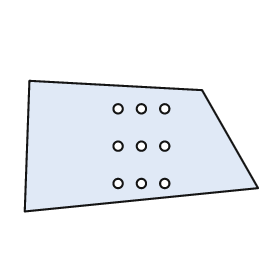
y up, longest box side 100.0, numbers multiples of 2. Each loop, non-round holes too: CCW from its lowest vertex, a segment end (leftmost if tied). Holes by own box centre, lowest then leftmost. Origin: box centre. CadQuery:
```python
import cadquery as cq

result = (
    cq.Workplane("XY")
    .moveTo(-50.0, -28.0)
    .lineTo(50.0, -18.0)
    .lineTo(26.0, 24.0)
    .lineTo(-48.0, 28.0)
    .close()
    .moveTo(-10.0, -16.0)
    .circle(2.0)
    .moveTo(0.0, -16.0)
    .circle(2.0)
    .moveTo(10.0, -16.0)
    .circle(2.0)
    .moveTo(-10.0, 0.0)
    .circle(2.0)
    .moveTo(0.0, 0.0)
    .circle(2.0)
    .moveTo(10.0, 0.0)
    .circle(2.0)
    .moveTo(-10.0, 16.0)
    .circle(2.0)
    .moveTo(0.0, 16.0)
    .circle(2.0)
    .moveTo(10.0, 16.0)
    .circle(2.0)
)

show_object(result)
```